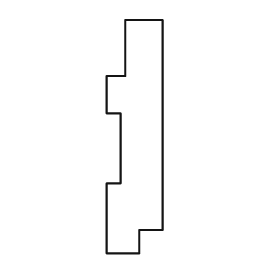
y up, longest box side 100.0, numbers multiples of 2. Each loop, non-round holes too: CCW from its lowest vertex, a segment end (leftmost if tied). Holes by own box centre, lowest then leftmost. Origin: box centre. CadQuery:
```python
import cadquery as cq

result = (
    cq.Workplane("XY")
    .moveTo(-12.0, -50.0)
    .lineTo(2.0, -50.0)
    .lineTo(2.0, -40.0)
    .lineTo(12.0, -40.0)
    .lineTo(12.0, 50.0)
    .lineTo(-4.0, 50.0)
    .lineTo(-4.0, 26.0)
    .lineTo(-12.0, 26.0)
    .lineTo(-12.0, 10.0)
    .lineTo(-6.0, 10.0)
    .lineTo(-6.0, -20.0)
    .lineTo(-12.0, -20.0)
    .close()
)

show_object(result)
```